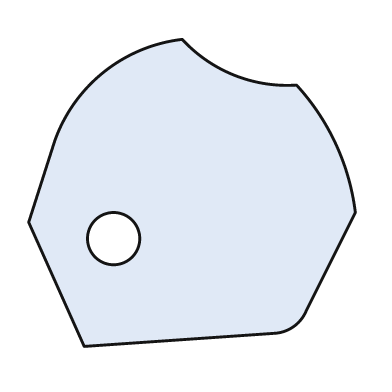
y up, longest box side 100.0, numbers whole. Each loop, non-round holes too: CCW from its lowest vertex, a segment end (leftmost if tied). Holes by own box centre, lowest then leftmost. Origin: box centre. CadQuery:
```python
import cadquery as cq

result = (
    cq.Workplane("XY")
    .moveTo(-33.0, -47.0)
    .lineTo(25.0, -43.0)
    .threePointArc((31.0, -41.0), (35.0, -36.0))
    .lineTo(50.0, -6.0)
    .threePointArc((44.0, 15.0), (32.0, 33.0))
    .threePointArc((13.0, 36.0), (-3.0, 47.0))
    .threePointArc((-27.0, 37.0), (-42.0, 16.0))
    .lineTo(-50.0, -9.0)
    .close()
    .moveTo(-24.0, -14.0)
    .circle(8.0)
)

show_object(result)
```